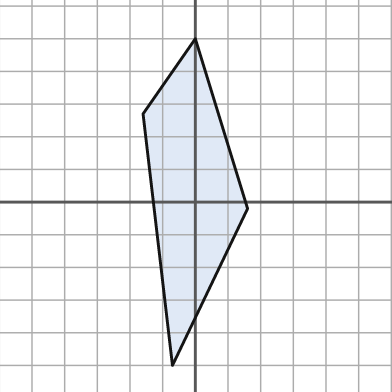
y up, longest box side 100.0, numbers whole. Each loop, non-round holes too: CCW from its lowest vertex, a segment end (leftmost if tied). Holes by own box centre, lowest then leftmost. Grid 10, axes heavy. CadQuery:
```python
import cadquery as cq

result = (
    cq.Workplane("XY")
    .moveTo(-7.0, -50.0)
    .lineTo(16.0, -2.0)
    .lineTo(0.0, 50.0)
    .lineTo(-16.0, 27.0)
    .close()
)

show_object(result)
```